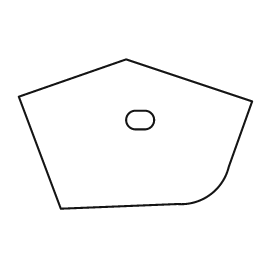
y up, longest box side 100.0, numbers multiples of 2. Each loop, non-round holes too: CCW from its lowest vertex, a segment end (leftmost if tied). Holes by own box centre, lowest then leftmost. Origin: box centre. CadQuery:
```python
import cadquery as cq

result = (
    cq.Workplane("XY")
    .moveTo(-32.0, -32.0)
    .lineTo(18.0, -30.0)
    .threePointArc((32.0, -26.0), (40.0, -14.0))
    .lineTo(50.0, 14.0)
    .lineTo(-4.0, 32.0)
    .lineTo(-50.0, 16.0)
    .close()
    .moveTo(0.0, 2.0)
    .lineTo(4.0, 2.0)
    .threePointArc((8.0, 6.0), (4.0, 10.0))
    .lineTo(0.0, 10.0)
    .threePointArc((-4.0, 6.0), (0.0, 2.0))
    .close()
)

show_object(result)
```